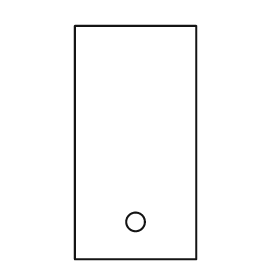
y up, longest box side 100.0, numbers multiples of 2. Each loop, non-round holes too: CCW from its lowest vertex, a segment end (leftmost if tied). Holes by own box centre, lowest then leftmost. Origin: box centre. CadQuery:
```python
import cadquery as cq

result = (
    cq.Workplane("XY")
    .moveTo(-26.0, -50.0)
    .lineTo(26.0, -50.0)
    .lineTo(26.0, 50.0)
    .lineTo(-26.0, 50.0)
    .close()
    .moveTo(0.0, -34.0)
    .circle(4.0)
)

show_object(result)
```